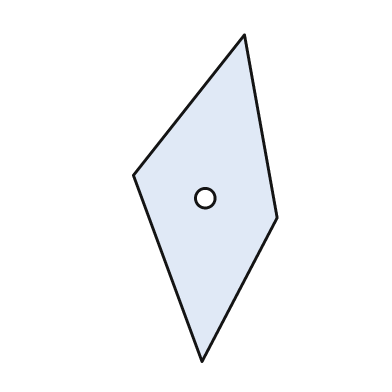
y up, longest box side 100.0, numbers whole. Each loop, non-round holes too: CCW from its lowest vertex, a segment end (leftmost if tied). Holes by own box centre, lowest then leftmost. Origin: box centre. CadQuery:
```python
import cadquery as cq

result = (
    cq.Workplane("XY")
    .moveTo(-1.0, -50.0)
    .lineTo(22.0, -6.0)
    .lineTo(12.0, 50.0)
    .lineTo(-22.0, 7.0)
    .close()
    .moveTo(0.0, 0.0)
    .circle(3.0)
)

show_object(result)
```